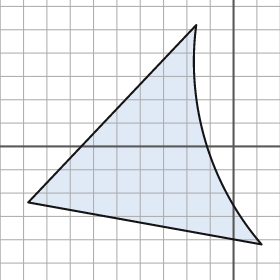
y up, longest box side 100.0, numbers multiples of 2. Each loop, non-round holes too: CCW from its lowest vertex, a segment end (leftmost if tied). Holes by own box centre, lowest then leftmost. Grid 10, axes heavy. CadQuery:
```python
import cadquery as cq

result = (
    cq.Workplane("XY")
    .moveTo(12.0, -42.0)
    .threePointArc((-12.0, 2.0), (-16.0, 52.0))
    .lineTo(-88.0, -24.0)
    .close()
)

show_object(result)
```